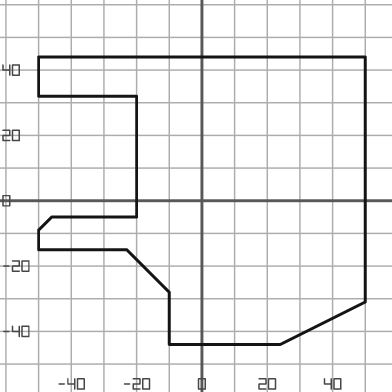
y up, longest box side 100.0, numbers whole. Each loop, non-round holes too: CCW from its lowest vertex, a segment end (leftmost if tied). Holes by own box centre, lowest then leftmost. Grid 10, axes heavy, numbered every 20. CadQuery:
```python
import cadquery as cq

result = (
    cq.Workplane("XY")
    .moveTo(-10.0, -44.0)
    .lineTo(24.0, -44.0)
    .lineTo(50.0, -31.0)
    .lineTo(50.0, 44.0)
    .lineTo(-50.0, 44.0)
    .lineTo(-50.0, 32.0)
    .lineTo(-20.0, 32.0)
    .lineTo(-20.0, -5.0)
    .lineTo(-46.0, -5.0)
    .lineTo(-50.0, -9.0)
    .lineTo(-50.0, -15.0)
    .lineTo(-23.0, -15.0)
    .lineTo(-10.0, -28.0)
    .close()
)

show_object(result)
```